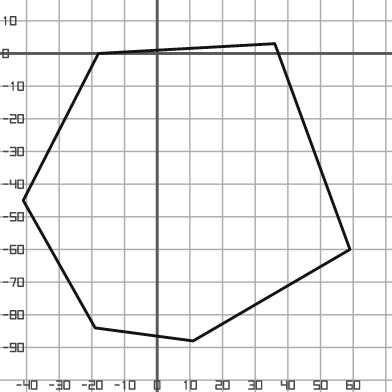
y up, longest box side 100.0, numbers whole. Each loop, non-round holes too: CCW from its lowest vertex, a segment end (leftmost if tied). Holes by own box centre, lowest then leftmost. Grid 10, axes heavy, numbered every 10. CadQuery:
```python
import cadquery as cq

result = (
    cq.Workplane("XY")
    .moveTo(11.0, -88.0)
    .lineTo(59.0, -60.0)
    .lineTo(36.0, 3.0)
    .lineTo(-18.0, 0.0)
    .lineTo(-41.0, -45.0)
    .lineTo(-19.0, -84.0)
    .close()
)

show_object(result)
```